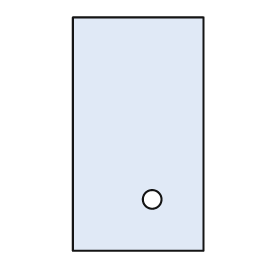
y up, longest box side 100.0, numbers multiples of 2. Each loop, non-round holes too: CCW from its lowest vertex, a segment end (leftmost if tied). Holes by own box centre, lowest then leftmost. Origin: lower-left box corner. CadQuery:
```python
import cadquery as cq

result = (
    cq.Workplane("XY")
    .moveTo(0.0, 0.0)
    .lineTo(56.0, 0.0)
    .lineTo(56.0, 100.0)
    .lineTo(0.0, 100.0)
    .close()
    .moveTo(34.0, 22.0)
    .circle(4.0)
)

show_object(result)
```